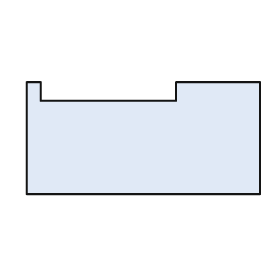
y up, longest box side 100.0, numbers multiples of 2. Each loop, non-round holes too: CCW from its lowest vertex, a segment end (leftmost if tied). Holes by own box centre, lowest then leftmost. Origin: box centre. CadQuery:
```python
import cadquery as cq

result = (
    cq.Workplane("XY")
    .moveTo(-50.0, -24.0)
    .lineTo(50.0, -24.0)
    .lineTo(50.0, 24.0)
    .lineTo(14.0, 24.0)
    .lineTo(14.0, 16.0)
    .lineTo(-44.0, 16.0)
    .lineTo(-44.0, 24.0)
    .lineTo(-50.0, 24.0)
    .close()
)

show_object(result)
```